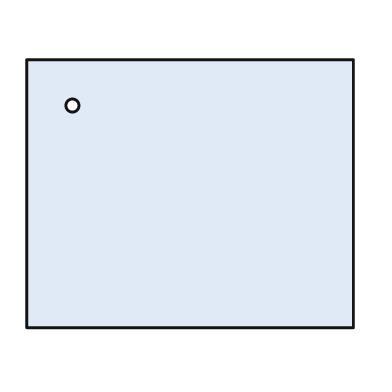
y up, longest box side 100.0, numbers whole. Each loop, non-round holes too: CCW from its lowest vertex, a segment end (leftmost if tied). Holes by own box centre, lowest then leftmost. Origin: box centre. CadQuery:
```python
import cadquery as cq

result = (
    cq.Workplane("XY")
    .moveTo(-50.0, -41.0)
    .lineTo(50.0, -41.0)
    .lineTo(50.0, 41.0)
    .lineTo(-50.0, 41.0)
    .close()
    .moveTo(-36.0, 27.0)
    .circle(2.0)
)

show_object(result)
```